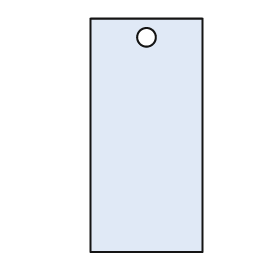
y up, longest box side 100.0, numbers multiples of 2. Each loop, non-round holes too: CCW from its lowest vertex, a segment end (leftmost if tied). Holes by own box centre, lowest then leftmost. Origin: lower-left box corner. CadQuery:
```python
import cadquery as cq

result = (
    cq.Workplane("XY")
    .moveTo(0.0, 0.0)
    .lineTo(48.0, 0.0)
    .lineTo(48.0, 100.0)
    .lineTo(0.0, 100.0)
    .close()
    .moveTo(24.0, 92.0)
    .circle(4.0)
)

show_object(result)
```